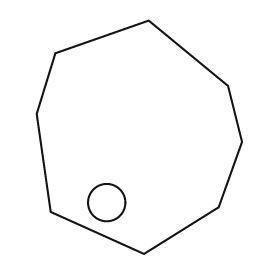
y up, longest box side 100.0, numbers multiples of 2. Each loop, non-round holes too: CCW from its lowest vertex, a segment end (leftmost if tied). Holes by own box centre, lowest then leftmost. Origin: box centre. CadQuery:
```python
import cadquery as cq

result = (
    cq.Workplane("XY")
    .moveTo(2.0, -50.0)
    .lineTo(34.0, -30.0)
    .lineTo(44.0, -2.0)
    .lineTo(38.0, 22.0)
    .lineTo(4.0, 50.0)
    .lineTo(-36.0, 36.0)
    .lineTo(-44.0, 10.0)
    .lineTo(-38.0, -32.0)
    .close()
    .moveTo(-14.0, -28.0)
    .circle(8.0)
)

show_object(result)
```